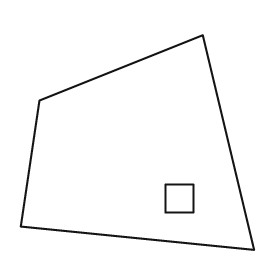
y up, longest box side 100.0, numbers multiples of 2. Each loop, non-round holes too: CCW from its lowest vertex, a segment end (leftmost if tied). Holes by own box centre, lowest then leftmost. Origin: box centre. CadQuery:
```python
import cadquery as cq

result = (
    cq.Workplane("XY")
    .moveTo(50.0, -46.0)
    .lineTo(28.0, 46.0)
    .lineTo(-42.0, 18.0)
    .lineTo(-50.0, -36.0)
    .close()
    .moveTo(12.0, -30.0)
    .lineTo(24.0, -30.0)
    .lineTo(24.0, -18.0)
    .lineTo(12.0, -18.0)
    .close()
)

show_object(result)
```